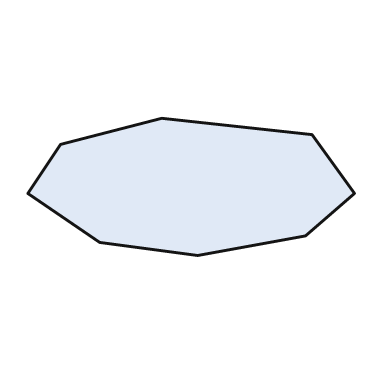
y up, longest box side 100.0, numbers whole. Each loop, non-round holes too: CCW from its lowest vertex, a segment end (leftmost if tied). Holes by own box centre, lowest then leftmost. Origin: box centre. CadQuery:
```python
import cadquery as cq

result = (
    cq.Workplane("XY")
    .moveTo(2.0, -21.0)
    .lineTo(35.0, -15.0)
    .lineTo(50.0, -2.0)
    .lineTo(37.0, 16.0)
    .lineTo(-9.0, 21.0)
    .lineTo(-40.0, 13.0)
    .lineTo(-50.0, -2.0)
    .lineTo(-28.0, -17.0)
    .close()
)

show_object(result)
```